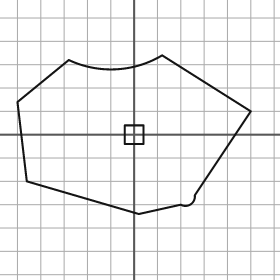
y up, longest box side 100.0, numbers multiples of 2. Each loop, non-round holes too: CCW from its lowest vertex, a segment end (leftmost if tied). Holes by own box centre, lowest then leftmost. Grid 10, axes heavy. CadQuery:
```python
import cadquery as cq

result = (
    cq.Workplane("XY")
    .moveTo(2.0, -34.0)
    .lineTo(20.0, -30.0)
    .threePointArc((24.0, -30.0), (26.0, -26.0))
    .lineTo(50.0, 10.0)
    .lineTo(12.0, 34.0)
    .threePointArc((-8.0, 28.0), (-28.0, 32.0))
    .lineTo(-50.0, 14.0)
    .lineTo(-46.0, -20.0)
    .close()
    .moveTo(-4.0, -4.0)
    .lineTo(4.0, -4.0)
    .lineTo(4.0, 4.0)
    .lineTo(-4.0, 4.0)
    .close()
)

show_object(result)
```